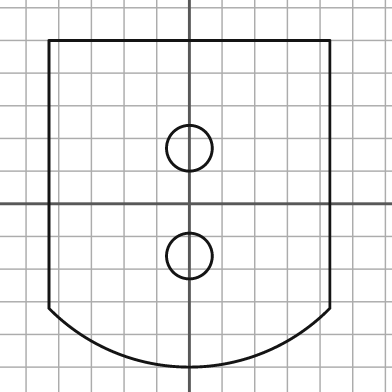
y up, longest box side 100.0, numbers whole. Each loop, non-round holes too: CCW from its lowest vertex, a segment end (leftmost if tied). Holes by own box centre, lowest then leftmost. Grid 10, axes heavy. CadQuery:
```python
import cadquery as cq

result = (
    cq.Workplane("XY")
    .moveTo(-43.0, -32.0)
    .threePointArc((0.0, -50.0), (43.0, -32.0))
    .lineTo(43.0, 50.0)
    .lineTo(-43.0, 50.0)
    .close()
    .moveTo(0.0, -16.0)
    .circle(7.0)
    .moveTo(0.0, 17.0)
    .circle(7.0)
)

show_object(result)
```